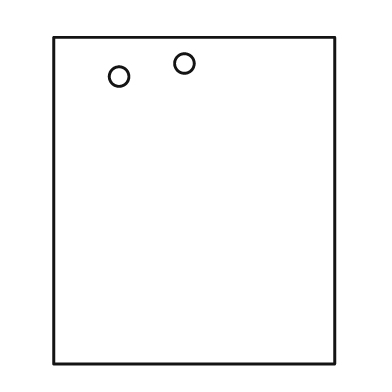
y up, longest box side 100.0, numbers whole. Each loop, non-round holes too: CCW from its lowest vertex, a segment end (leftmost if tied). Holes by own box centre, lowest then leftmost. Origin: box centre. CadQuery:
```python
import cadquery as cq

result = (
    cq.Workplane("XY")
    .moveTo(-43.0, -50.0)
    .lineTo(43.0, -50.0)
    .lineTo(43.0, 50.0)
    .lineTo(-43.0, 50.0)
    .close()
    .moveTo(-23.0, 38.0)
    .circle(3.0)
    .moveTo(-3.0, 42.0)
    .circle(3.0)
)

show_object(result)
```